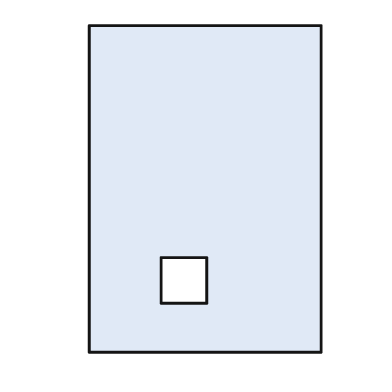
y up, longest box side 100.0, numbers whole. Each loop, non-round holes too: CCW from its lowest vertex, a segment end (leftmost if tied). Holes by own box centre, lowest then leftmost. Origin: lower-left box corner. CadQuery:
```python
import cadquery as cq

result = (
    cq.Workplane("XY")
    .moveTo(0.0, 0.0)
    .lineTo(71.0, 0.0)
    .lineTo(71.0, 100.0)
    .lineTo(0.0, 100.0)
    .close()
    .moveTo(22.0, 15.0)
    .lineTo(36.0, 15.0)
    .lineTo(36.0, 29.0)
    .lineTo(22.0, 29.0)
    .close()
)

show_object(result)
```